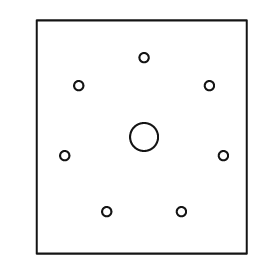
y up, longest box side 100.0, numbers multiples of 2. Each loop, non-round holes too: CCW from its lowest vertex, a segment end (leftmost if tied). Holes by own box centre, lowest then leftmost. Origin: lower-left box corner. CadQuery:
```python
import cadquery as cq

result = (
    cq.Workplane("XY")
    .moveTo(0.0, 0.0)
    .lineTo(90.0, 0.0)
    .lineTo(90.0, 100.0)
    .lineTo(0.0, 100.0)
    .close()
    .moveTo(30.0, 18.0)
    .circle(2.0)
    .moveTo(62.0, 18.0)
    .circle(2.0)
    .moveTo(12.0, 42.0)
    .circle(2.0)
    .moveTo(80.0, 42.0)
    .circle(2.0)
    .moveTo(46.0, 50.0)
    .circle(6.0)
    .moveTo(18.0, 72.0)
    .circle(2.0)
    .moveTo(74.0, 72.0)
    .circle(2.0)
    .moveTo(46.0, 84.0)
    .circle(2.0)
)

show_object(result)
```